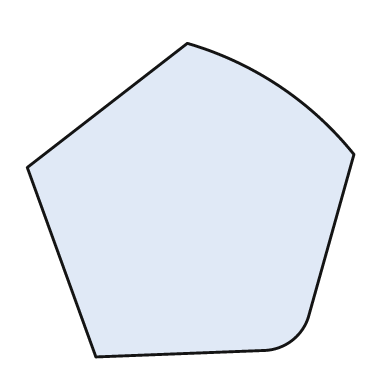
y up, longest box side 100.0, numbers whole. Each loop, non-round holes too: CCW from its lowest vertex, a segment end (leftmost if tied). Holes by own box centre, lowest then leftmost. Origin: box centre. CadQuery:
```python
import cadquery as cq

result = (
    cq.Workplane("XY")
    .moveTo(-29.0, -48.0)
    .lineTo(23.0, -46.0)
    .threePointArc((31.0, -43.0), (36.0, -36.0))
    .lineTo(50.0, 14.0)
    .threePointArc((27.0, 35.0), (-1.0, 48.0))
    .lineTo(-50.0, 10.0)
    .close()
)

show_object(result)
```